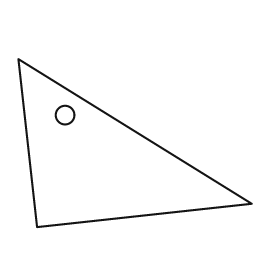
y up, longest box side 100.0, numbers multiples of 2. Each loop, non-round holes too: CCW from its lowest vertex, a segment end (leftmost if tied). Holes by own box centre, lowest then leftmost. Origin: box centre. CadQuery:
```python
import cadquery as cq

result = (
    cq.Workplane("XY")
    .moveTo(-42.0, -36.0)
    .lineTo(50.0, -26.0)
    .lineTo(-50.0, 36.0)
    .close()
    .moveTo(-30.0, 12.0)
    .circle(4.0)
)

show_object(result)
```